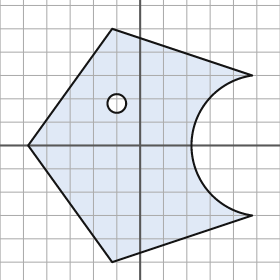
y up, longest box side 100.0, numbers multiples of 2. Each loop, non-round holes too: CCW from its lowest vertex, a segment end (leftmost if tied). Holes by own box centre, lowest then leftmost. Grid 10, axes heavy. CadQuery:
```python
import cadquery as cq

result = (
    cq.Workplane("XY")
    .moveTo(-12.0, -50.0)
    .lineTo(48.0, -30.0)
    .threePointArc((22.0, 0.0), (48.0, 30.0))
    .lineTo(-12.0, 50.0)
    .lineTo(-48.0, 0.0)
    .close()
    .moveTo(-10.0, 18.0)
    .circle(4.0)
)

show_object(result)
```